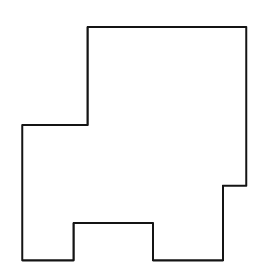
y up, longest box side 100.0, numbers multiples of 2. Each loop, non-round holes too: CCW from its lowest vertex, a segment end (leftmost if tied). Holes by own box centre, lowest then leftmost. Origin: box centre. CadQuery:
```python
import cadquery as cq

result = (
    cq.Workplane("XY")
    .moveTo(-48.0, -50.0)
    .lineTo(-26.0, -50.0)
    .lineTo(-26.0, -34.0)
    .lineTo(8.0, -34.0)
    .lineTo(8.0, -50.0)
    .lineTo(38.0, -50.0)
    .lineTo(38.0, -18.0)
    .lineTo(48.0, -18.0)
    .lineTo(48.0, 50.0)
    .lineTo(-20.0, 50.0)
    .lineTo(-20.0, 8.0)
    .lineTo(-48.0, 8.0)
    .close()
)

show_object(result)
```